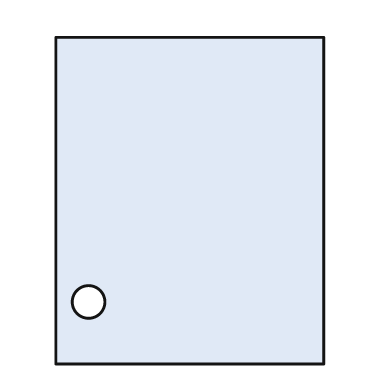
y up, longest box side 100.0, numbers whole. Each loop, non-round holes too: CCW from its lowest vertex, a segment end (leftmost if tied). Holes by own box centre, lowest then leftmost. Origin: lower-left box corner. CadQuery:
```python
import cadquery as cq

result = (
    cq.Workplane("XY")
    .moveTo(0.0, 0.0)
    .lineTo(82.0, 0.0)
    .lineTo(82.0, 100.0)
    .lineTo(0.0, 100.0)
    .close()
    .moveTo(10.0, 19.0)
    .circle(5.0)
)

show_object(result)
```